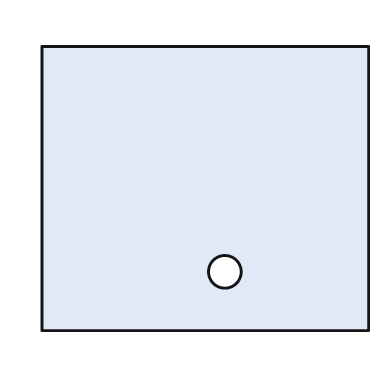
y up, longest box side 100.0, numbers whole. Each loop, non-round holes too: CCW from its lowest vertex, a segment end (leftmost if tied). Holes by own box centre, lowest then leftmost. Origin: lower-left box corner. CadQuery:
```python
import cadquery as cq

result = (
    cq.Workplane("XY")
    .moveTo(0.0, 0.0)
    .lineTo(100.0, 0.0)
    .lineTo(100.0, 87.0)
    .lineTo(0.0, 87.0)
    .close()
    .moveTo(56.0, 18.0)
    .circle(5.0)
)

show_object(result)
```